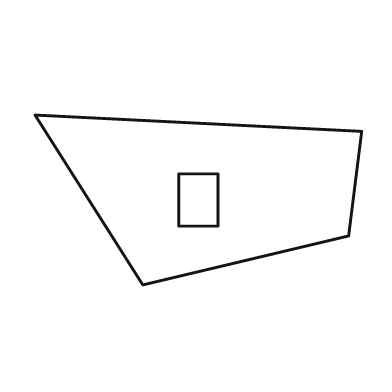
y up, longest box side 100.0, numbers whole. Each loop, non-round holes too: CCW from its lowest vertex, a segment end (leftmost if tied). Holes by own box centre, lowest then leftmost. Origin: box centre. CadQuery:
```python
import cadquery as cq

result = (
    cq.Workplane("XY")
    .moveTo(-17.0, -26.0)
    .lineTo(46.0, -11.0)
    .lineTo(50.0, 21.0)
    .lineTo(-50.0, 26.0)
    .close()
    .moveTo(-6.0, -8.0)
    .lineTo(6.0, -8.0)
    .lineTo(6.0, 8.0)
    .lineTo(-6.0, 8.0)
    .close()
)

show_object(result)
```